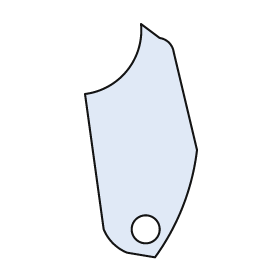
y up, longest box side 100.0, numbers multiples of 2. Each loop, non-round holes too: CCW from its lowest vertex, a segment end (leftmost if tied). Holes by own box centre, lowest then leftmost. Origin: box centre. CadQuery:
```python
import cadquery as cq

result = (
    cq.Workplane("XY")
    .moveTo(6.0, -50.0)
    .threePointArc((18.0, -28.0), (24.0, -4.0))
    .lineTo(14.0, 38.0)
    .threePointArc((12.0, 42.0), (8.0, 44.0))
    .lineTo(0.0, 50.0)
    .threePointArc((-6.0, 30.0), (-24.0, 20.0))
    .lineTo(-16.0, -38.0)
    .threePointArc((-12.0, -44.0), (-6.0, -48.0))
    .close()
    .moveTo(2.0, -38.0)
    .circle(6.0)
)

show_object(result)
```